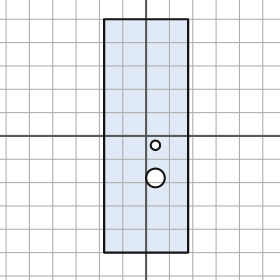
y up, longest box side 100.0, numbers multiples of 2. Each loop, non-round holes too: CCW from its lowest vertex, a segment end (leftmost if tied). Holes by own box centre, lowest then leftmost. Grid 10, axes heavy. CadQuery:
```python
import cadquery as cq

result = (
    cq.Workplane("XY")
    .moveTo(-18.0, -50.0)
    .lineTo(18.0, -50.0)
    .lineTo(18.0, 50.0)
    .lineTo(-18.0, 50.0)
    .close()
    .moveTo(4.0, -18.0)
    .circle(4.0)
    .moveTo(4.0, -4.0)
    .circle(2.0)
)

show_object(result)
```